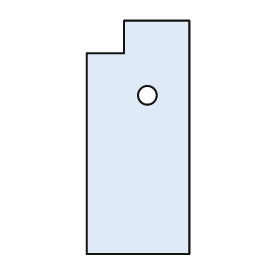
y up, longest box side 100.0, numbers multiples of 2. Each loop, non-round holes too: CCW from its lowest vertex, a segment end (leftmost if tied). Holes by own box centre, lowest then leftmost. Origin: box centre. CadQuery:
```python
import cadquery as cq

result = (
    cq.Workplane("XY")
    .moveTo(-22.0, -50.0)
    .lineTo(22.0, -50.0)
    .lineTo(22.0, 50.0)
    .lineTo(-6.0, 50.0)
    .lineTo(-6.0, 36.0)
    .lineTo(-22.0, 36.0)
    .close()
    .moveTo(4.0, 18.0)
    .circle(4.0)
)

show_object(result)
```